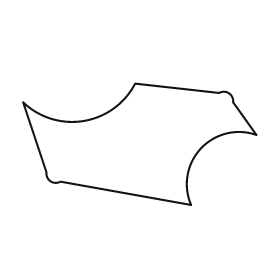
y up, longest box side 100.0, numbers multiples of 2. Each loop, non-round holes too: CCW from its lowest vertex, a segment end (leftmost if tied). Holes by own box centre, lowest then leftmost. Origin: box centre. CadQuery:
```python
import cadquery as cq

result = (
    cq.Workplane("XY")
    .moveTo(22.0, -26.0)
    .threePointArc((26.0, -2.0), (50.0, 4.0))
    .lineTo(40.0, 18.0)
    .threePointArc((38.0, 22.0), (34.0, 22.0))
    .lineTo(-2.0, 26.0)
    .threePointArc((-24.0, 10.0), (-50.0, 18.0))
    .lineTo(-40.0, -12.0)
    .threePointArc((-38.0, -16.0), (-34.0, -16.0))
    .close()
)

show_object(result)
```